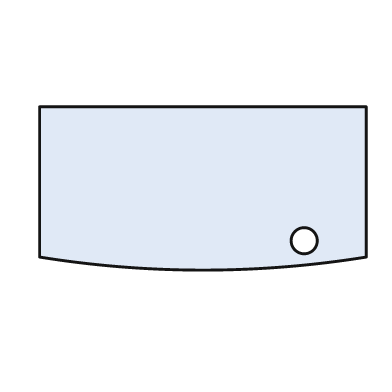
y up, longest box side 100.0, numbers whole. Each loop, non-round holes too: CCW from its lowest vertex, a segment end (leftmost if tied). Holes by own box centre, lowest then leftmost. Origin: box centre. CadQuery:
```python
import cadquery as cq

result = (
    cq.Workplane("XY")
    .moveTo(-50.0, -21.0)
    .threePointArc((0.0, -25.0), (50.0, -21.0))
    .lineTo(50.0, 25.0)
    .lineTo(-50.0, 25.0)
    .close()
    .moveTo(31.0, -16.0)
    .circle(4.0)
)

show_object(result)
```